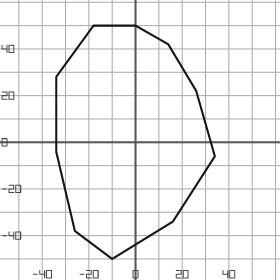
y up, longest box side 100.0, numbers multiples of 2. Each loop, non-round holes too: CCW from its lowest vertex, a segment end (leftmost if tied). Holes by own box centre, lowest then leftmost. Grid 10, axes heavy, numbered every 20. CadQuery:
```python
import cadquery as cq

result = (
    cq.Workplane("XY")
    .moveTo(-10.0, -50.0)
    .lineTo(16.0, -34.0)
    .lineTo(34.0, -6.0)
    .lineTo(26.0, 22.0)
    .lineTo(14.0, 42.0)
    .lineTo(0.0, 50.0)
    .lineTo(-18.0, 50.0)
    .lineTo(-34.0, 28.0)
    .lineTo(-34.0, -4.0)
    .lineTo(-26.0, -38.0)
    .close()
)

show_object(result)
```